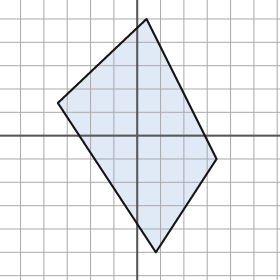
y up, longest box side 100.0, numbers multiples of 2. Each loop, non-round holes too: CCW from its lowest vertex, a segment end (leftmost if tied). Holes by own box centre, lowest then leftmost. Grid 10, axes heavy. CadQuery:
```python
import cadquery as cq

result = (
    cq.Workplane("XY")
    .moveTo(8.0, -50.0)
    .lineTo(34.0, -10.0)
    .lineTo(4.0, 50.0)
    .lineTo(-34.0, 14.0)
    .close()
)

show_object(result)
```